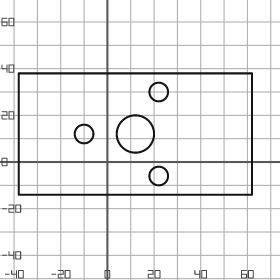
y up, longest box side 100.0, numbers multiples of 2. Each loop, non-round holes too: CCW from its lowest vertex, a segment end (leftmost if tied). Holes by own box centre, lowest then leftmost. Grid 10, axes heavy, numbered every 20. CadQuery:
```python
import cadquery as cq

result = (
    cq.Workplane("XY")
    .moveTo(-38.0, -14.0)
    .lineTo(62.0, -14.0)
    .lineTo(62.0, 38.0)
    .lineTo(-38.0, 38.0)
    .close()
    .moveTo(22.0, -6.0)
    .circle(4.0)
    .moveTo(-10.0, 12.0)
    .circle(4.0)
    .moveTo(12.0, 12.0)
    .circle(8.0)
    .moveTo(22.0, 30.0)
    .circle(4.0)
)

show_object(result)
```